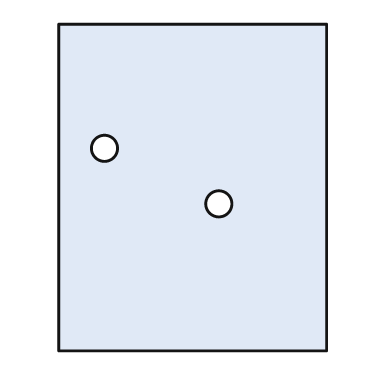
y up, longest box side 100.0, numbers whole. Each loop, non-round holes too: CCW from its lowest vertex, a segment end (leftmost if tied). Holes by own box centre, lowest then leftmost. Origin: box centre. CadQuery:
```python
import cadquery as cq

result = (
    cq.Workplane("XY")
    .moveTo(-41.0, -50.0)
    .lineTo(41.0, -50.0)
    .lineTo(41.0, 50.0)
    .lineTo(-41.0, 50.0)
    .close()
    .moveTo(8.0, -5.0)
    .circle(4.0)
    .moveTo(-27.0, 12.0)
    .circle(4.0)
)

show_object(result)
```